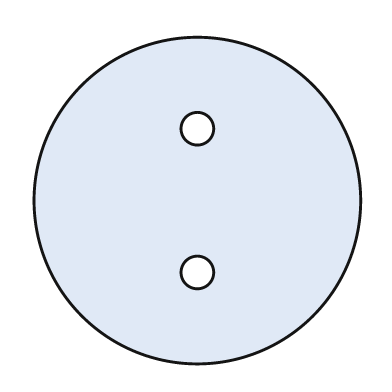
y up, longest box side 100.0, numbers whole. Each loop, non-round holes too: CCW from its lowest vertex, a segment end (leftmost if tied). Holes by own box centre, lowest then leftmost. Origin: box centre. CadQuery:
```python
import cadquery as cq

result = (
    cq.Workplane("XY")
    .moveTo(0.0, 0.0)
    .circle(50.0)
    .moveTo(0.0, -22.0)
    .circle(5.0)
    .moveTo(0.0, 22.0)
    .circle(5.0)
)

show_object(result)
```